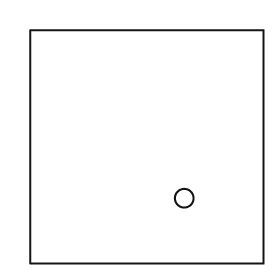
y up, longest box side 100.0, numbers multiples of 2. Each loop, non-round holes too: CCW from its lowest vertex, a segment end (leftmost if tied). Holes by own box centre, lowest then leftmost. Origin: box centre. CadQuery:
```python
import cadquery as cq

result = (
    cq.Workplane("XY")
    .moveTo(-50.0, -50.0)
    .lineTo(50.0, -50.0)
    .lineTo(50.0, 50.0)
    .lineTo(-50.0, 50.0)
    .close()
    .moveTo(16.0, -22.0)
    .circle(4.0)
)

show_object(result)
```